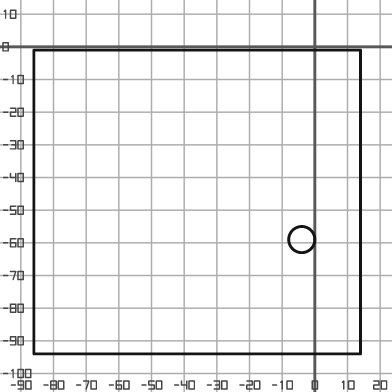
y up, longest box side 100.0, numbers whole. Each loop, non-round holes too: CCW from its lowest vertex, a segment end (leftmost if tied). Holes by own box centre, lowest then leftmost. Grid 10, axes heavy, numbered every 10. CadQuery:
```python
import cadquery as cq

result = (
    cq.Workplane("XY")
    .moveTo(-86.0, -94.0)
    .lineTo(14.0, -94.0)
    .lineTo(14.0, -1.0)
    .lineTo(-86.0, -1.0)
    .close()
    .moveTo(-4.0, -59.0)
    .circle(4.0)
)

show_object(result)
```